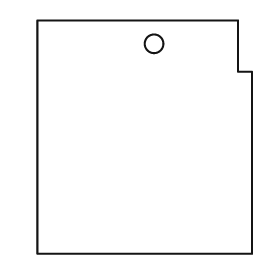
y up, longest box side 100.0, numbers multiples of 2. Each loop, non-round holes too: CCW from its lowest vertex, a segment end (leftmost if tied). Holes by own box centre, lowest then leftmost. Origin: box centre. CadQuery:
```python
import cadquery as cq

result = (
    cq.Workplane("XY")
    .moveTo(-46.0, -50.0)
    .lineTo(46.0, -50.0)
    .lineTo(46.0, 28.0)
    .lineTo(40.0, 28.0)
    .lineTo(40.0, 50.0)
    .lineTo(-46.0, 50.0)
    .close()
    .moveTo(4.0, 40.0)
    .circle(4.0)
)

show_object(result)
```